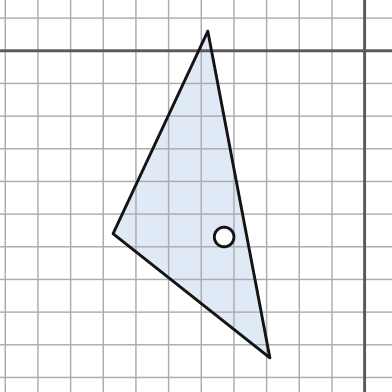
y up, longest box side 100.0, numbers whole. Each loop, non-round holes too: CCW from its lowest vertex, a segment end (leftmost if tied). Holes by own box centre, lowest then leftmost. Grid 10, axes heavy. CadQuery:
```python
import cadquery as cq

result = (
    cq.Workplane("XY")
    .moveTo(-29.0, -94.0)
    .lineTo(-48.0, 6.0)
    .lineTo(-77.0, -56.0)
    .close()
    .moveTo(-43.0, -57.0)
    .circle(3.0)
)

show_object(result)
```